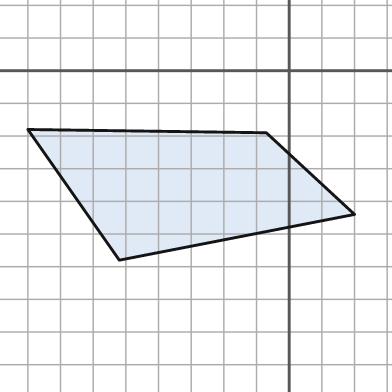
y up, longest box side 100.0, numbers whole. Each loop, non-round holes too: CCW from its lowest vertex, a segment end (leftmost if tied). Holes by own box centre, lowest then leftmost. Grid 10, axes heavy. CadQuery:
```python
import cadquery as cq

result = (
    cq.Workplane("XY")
    .moveTo(-52.0, -58.0)
    .lineTo(20.0, -44.0)
    .lineTo(-7.0, -19.0)
    .lineTo(-80.0, -18.0)
    .close()
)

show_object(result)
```